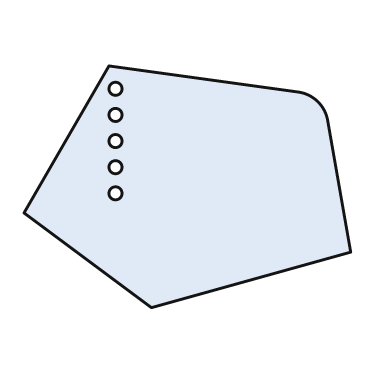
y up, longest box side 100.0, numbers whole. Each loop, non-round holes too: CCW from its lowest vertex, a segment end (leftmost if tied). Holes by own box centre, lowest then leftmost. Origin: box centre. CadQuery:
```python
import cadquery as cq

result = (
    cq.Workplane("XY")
    .moveTo(-11.0, -37.0)
    .lineTo(50.0, -20.0)
    .lineTo(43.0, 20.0)
    .threePointArc((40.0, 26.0), (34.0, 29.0))
    .lineTo(-24.0, 37.0)
    .lineTo(-50.0, -8.0)
    .close()
    .moveTo(-22.0, -2.0)
    .circle(2.0)
    .moveTo(-22.0, 6.0)
    .circle(2.0)
    .moveTo(-22.0, 14.0)
    .circle(2.0)
    .moveTo(-22.0, 22.0)
    .circle(2.0)
    .moveTo(-22.0, 30.0)
    .circle(2.0)
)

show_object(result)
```